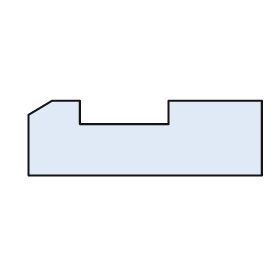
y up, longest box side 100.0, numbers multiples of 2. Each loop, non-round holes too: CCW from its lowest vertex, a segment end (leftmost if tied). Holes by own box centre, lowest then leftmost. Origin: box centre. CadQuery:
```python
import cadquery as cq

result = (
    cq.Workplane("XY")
    .moveTo(-50.0, -16.0)
    .lineTo(50.0, -16.0)
    .lineTo(50.0, 16.0)
    .lineTo(10.0, 16.0)
    .lineTo(10.0, 6.0)
    .lineTo(-28.0, 6.0)
    .lineTo(-28.0, 16.0)
    .lineTo(-40.0, 16.0)
    .lineTo(-50.0, 10.0)
    .close()
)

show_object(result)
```